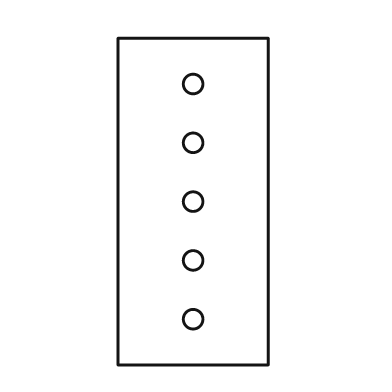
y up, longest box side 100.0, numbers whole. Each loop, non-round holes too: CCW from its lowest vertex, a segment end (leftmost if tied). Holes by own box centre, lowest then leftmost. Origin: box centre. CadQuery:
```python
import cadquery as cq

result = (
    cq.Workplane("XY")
    .moveTo(-23.0, -50.0)
    .lineTo(23.0, -50.0)
    .lineTo(23.0, 50.0)
    .lineTo(-23.0, 50.0)
    .close()
    .moveTo(0.0, -36.0)
    .circle(3.0)
    .moveTo(0.0, -18.0)
    .circle(3.0)
    .moveTo(0.0, 0.0)
    .circle(3.0)
    .moveTo(0.0, 18.0)
    .circle(3.0)
    .moveTo(0.0, 36.0)
    .circle(3.0)
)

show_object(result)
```